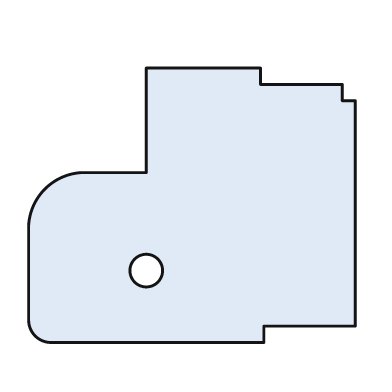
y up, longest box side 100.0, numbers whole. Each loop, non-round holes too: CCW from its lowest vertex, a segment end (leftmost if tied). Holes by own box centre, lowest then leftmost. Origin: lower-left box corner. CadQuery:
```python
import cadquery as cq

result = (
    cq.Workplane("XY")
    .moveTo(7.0, 0.0)
    .lineTo(72.0, 0.0)
    .lineTo(72.0, 5.0)
    .lineTo(100.0, 5.0)
    .lineTo(100.0, 74.0)
    .lineTo(96.0, 74.0)
    .lineTo(96.0, 79.0)
    .lineTo(71.0, 79.0)
    .lineTo(71.0, 84.0)
    .lineTo(36.0, 84.0)
    .lineTo(36.0, 52.0)
    .lineTo(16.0, 52.0)
    .threePointArc((5.0, 47.0), (0.0, 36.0))
    .lineTo(0.0, 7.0)
    .threePointArc((2.0, 2.0), (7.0, 0.0))
    .close()
    .moveTo(36.0, 22.0)
    .circle(5.0)
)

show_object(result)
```